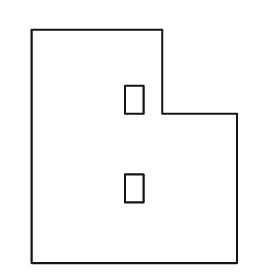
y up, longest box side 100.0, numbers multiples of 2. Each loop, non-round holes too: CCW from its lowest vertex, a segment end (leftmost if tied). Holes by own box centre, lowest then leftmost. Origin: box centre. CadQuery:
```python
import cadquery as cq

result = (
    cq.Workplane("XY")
    .moveTo(-44.0, -50.0)
    .lineTo(44.0, -50.0)
    .lineTo(44.0, 14.0)
    .lineTo(12.0, 14.0)
    .lineTo(12.0, 50.0)
    .lineTo(-44.0, 50.0)
    .close()
    .moveTo(-4.0, -24.0)
    .lineTo(4.0, -24.0)
    .lineTo(4.0, -12.0)
    .lineTo(-4.0, -12.0)
    .close()
    .moveTo(-4.0, 14.0)
    .lineTo(4.0, 14.0)
    .lineTo(4.0, 26.0)
    .lineTo(-4.0, 26.0)
    .close()
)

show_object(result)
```